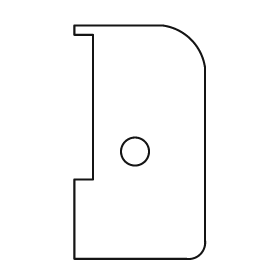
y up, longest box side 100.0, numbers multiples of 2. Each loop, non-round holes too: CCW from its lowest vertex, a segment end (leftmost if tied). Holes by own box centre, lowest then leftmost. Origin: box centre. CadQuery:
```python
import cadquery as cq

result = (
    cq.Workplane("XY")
    .moveTo(-28.0, -50.0)
    .lineTo(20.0, -50.0)
    .threePointArc((26.0, -48.0), (28.0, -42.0))
    .lineTo(28.0, 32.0)
    .threePointArc((22.0, 44.0), (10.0, 50.0))
    .lineTo(-28.0, 50.0)
    .lineTo(-28.0, 46.0)
    .lineTo(-20.0, 46.0)
    .lineTo(-20.0, -16.0)
    .lineTo(-28.0, -16.0)
    .close()
    .moveTo(-2.0, -4.0)
    .circle(6.0)
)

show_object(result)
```